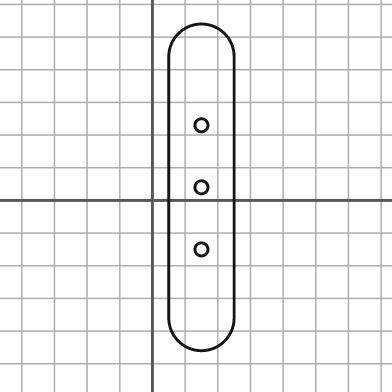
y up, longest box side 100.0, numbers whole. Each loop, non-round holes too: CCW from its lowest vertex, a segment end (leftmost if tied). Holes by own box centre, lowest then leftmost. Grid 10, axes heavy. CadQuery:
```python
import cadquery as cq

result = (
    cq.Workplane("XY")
    .moveTo(5.0, -36.0)
    .threePointArc((15.0, -46.0), (25.0, -36.0))
    .lineTo(25.0, 44.0)
    .threePointArc((15.0, 54.0), (5.0, 44.0))
    .close()
    .moveTo(15.0, -15.0)
    .circle(2.0)
    .moveTo(15.0, 4.0)
    .circle(2.0)
    .moveTo(15.0, 23.0)
    .circle(2.0)
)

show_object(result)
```